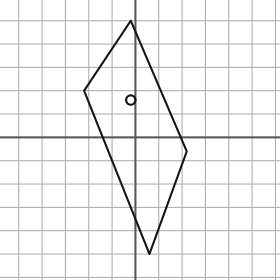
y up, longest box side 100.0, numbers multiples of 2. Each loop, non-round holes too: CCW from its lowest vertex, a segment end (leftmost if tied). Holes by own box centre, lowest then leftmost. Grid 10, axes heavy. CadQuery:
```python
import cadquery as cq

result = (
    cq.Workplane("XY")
    .moveTo(6.0, -50.0)
    .lineTo(22.0, -6.0)
    .lineTo(-2.0, 50.0)
    .lineTo(-22.0, 20.0)
    .close()
    .moveTo(-2.0, 16.0)
    .circle(2.0)
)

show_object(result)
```